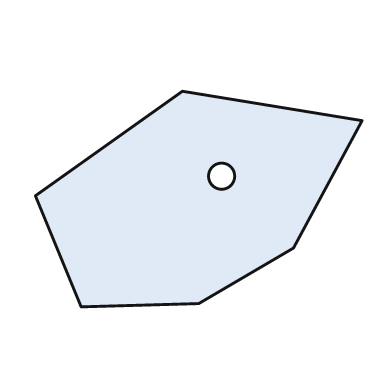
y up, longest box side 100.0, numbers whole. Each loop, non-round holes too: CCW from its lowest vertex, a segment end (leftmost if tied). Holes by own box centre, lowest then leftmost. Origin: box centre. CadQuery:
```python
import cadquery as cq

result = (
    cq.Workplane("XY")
    .moveTo(-36.0, -33.0)
    .lineTo(0.0, -32.0)
    .lineTo(29.0, -15.0)
    .lineTo(50.0, 24.0)
    .lineTo(-5.0, 33.0)
    .lineTo(-50.0, 1.0)
    .close()
    .moveTo(7.0, 7.0)
    .circle(4.0)
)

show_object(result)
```